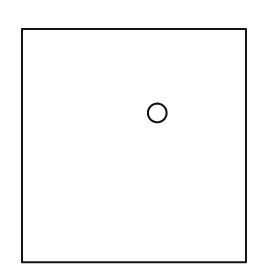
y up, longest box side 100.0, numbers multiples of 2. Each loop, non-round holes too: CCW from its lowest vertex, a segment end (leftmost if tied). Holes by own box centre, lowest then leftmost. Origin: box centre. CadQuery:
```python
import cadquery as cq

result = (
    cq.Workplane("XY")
    .moveTo(-48.0, -50.0)
    .lineTo(48.0, -50.0)
    .lineTo(48.0, 50.0)
    .lineTo(-48.0, 50.0)
    .close()
    .moveTo(10.0, 14.0)
    .circle(4.0)
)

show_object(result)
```